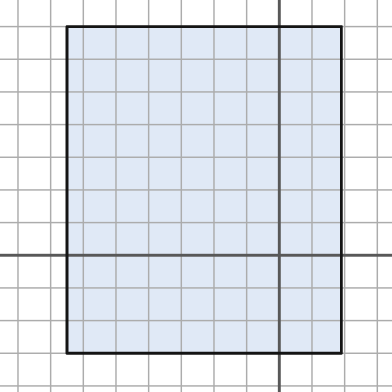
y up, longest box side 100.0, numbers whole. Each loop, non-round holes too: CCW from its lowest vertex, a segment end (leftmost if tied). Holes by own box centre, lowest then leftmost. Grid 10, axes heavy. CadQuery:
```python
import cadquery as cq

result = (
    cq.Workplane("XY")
    .moveTo(-65.0, -30.0)
    .lineTo(19.0, -30.0)
    .lineTo(19.0, 70.0)
    .lineTo(-65.0, 70.0)
    .close()
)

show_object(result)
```